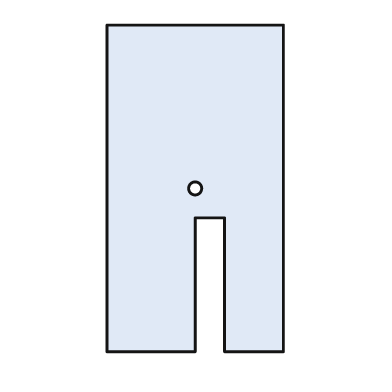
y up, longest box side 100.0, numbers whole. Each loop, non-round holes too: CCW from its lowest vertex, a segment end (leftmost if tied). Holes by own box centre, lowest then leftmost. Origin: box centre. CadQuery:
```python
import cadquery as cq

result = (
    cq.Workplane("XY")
    .moveTo(-27.0, -50.0)
    .lineTo(0.0, -50.0)
    .lineTo(0.0, -9.0)
    .lineTo(9.0, -9.0)
    .lineTo(9.0, -50.0)
    .lineTo(27.0, -50.0)
    .lineTo(27.0, 50.0)
    .lineTo(-27.0, 50.0)
    .close()
    .moveTo(0.0, 0.0)
    .circle(2.0)
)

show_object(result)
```